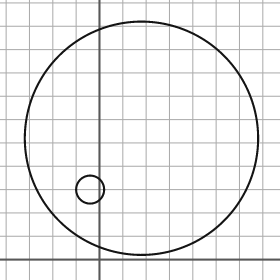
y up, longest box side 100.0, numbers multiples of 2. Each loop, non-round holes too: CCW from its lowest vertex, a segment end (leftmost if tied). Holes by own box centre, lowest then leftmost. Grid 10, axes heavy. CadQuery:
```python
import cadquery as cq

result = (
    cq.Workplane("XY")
    .moveTo(18.0, 52.0)
    .circle(50.0)
    .moveTo(-4.0, 30.0)
    .circle(6.0)
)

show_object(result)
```